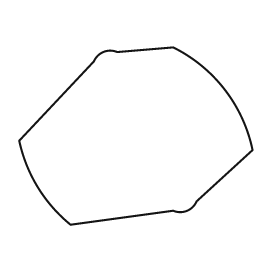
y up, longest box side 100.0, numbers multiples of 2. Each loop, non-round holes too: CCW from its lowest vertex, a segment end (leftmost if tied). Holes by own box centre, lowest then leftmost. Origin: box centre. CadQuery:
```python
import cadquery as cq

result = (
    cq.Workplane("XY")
    .moveTo(-28.0, -38.0)
    .lineTo(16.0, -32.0)
    .threePointArc((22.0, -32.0), (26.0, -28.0))
    .lineTo(50.0, -6.0)
    .threePointArc((38.0, 20.0), (16.0, 38.0))
    .lineTo(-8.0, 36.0)
    .threePointArc((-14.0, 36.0), (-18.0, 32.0))
    .lineTo(-50.0, -2.0)
    .threePointArc((-42.0, -22.0), (-28.0, -38.0))
    .close()
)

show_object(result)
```